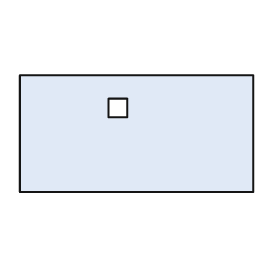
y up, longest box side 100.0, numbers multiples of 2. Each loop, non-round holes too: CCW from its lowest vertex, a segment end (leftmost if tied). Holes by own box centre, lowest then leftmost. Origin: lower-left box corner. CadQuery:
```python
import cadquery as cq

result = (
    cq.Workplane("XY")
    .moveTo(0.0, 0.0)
    .lineTo(100.0, 0.0)
    .lineTo(100.0, 50.0)
    .lineTo(0.0, 50.0)
    .close()
    .moveTo(38.0, 32.0)
    .lineTo(46.0, 32.0)
    .lineTo(46.0, 40.0)
    .lineTo(38.0, 40.0)
    .close()
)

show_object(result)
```